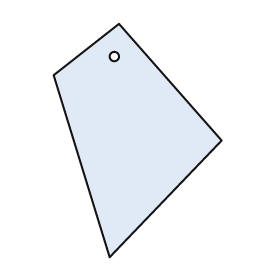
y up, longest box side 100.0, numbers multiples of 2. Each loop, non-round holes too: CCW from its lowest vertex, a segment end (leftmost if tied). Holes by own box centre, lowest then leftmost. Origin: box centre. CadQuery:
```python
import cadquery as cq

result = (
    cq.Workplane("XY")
    .moveTo(-12.0, -50.0)
    .lineTo(36.0, 0.0)
    .lineTo(-8.0, 50.0)
    .lineTo(-36.0, 28.0)
    .close()
    .moveTo(-10.0, 36.0)
    .circle(2.0)
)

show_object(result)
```